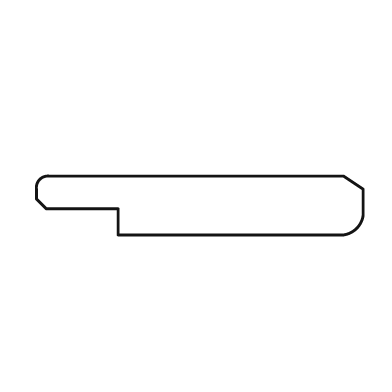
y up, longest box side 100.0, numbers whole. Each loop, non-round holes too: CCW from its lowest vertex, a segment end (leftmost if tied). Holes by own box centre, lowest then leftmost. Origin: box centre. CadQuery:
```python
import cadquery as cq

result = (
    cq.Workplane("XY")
    .moveTo(-25.0, -9.0)
    .lineTo(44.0, -9.0)
    .threePointArc((48.0, -7.0), (50.0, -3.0))
    .lineTo(50.0, 5.0)
    .lineTo(44.0, 9.0)
    .lineTo(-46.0, 9.0)
    .threePointArc((-49.0, 8.0), (-50.0, 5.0))
    .lineTo(-50.0, 2.0)
    .lineTo(-47.0, -1.0)
    .lineTo(-25.0, -1.0)
    .close()
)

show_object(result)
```